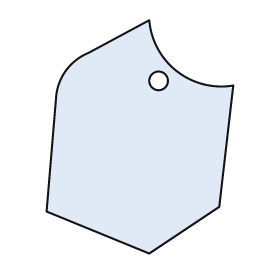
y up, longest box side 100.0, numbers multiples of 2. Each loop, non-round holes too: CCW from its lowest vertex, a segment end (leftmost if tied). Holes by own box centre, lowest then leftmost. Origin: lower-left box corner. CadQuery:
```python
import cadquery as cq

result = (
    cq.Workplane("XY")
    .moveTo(44.0, 0.0)
    .lineTo(74.0, 20.0)
    .lineTo(80.0, 72.0)
    .threePointArc((56.0, 78.0), (44.0, 100.0))
    .lineTo(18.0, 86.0)
    .threePointArc((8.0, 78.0), (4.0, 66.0))
    .lineTo(0.0, 18.0)
    .close()
    .moveTo(48.0, 74.0)
    .circle(4.0)
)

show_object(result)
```